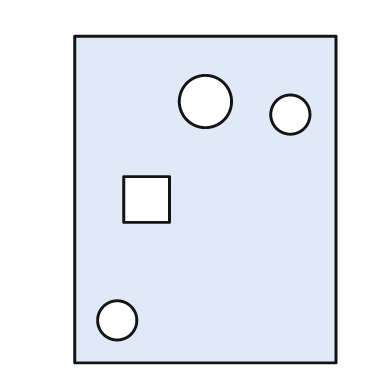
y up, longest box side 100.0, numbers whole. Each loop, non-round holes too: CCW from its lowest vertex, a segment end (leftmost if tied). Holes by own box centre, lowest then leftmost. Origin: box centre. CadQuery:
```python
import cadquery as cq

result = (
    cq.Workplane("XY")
    .moveTo(-40.0, -50.0)
    .lineTo(40.0, -50.0)
    .lineTo(40.0, 50.0)
    .lineTo(-40.0, 50.0)
    .close()
    .moveTo(-27.0, -37.0)
    .circle(6.0)
    .moveTo(-25.0, -7.0)
    .lineTo(-11.0, -7.0)
    .lineTo(-11.0, 7.0)
    .lineTo(-25.0, 7.0)
    .close()
    .moveTo(26.0, 26.0)
    .circle(6.0)
    .moveTo(0.0, 30.0)
    .circle(8.0)
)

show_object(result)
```